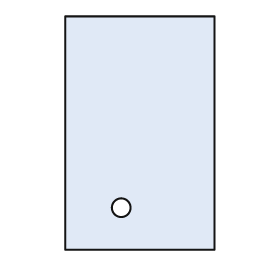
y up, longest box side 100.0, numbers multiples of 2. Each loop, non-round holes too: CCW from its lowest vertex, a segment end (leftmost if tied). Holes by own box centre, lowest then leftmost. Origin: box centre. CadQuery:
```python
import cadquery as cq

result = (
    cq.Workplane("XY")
    .moveTo(-32.0, -50.0)
    .lineTo(32.0, -50.0)
    .lineTo(32.0, 50.0)
    .lineTo(-32.0, 50.0)
    .close()
    .moveTo(-8.0, -32.0)
    .circle(4.0)
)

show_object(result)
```